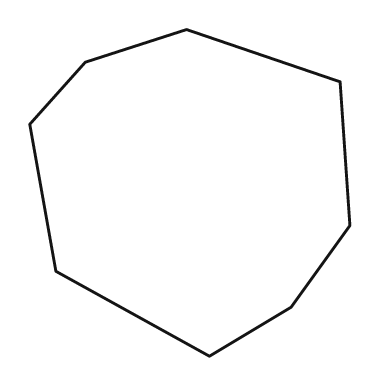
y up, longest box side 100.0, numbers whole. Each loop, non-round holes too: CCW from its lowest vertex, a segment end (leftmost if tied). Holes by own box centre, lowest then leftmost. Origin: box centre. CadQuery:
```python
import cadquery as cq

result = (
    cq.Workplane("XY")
    .moveTo(6.0, -50.0)
    .lineTo(31.0, -35.0)
    .lineTo(49.0, -10.0)
    .lineTo(46.0, 34.0)
    .lineTo(-1.0, 50.0)
    .lineTo(-32.0, 40.0)
    .lineTo(-49.0, 21.0)
    .lineTo(-41.0, -24.0)
    .close()
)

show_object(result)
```